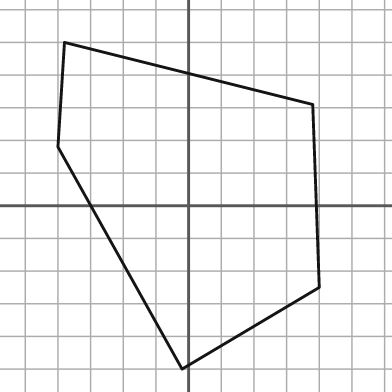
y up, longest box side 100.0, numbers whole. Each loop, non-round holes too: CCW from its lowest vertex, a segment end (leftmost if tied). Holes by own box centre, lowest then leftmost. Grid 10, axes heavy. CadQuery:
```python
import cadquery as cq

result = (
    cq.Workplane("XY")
    .moveTo(-2.0, -50.0)
    .lineTo(40.0, -25.0)
    .lineTo(38.0, 31.0)
    .lineTo(-38.0, 50.0)
    .lineTo(-40.0, 18.0)
    .close()
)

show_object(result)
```